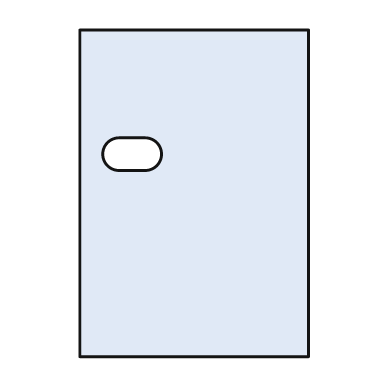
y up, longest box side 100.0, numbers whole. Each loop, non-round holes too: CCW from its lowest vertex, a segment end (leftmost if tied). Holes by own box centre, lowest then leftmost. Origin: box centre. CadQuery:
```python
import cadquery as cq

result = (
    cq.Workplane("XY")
    .moveTo(-35.0, -50.0)
    .lineTo(35.0, -50.0)
    .lineTo(35.0, 50.0)
    .lineTo(-35.0, 50.0)
    .close()
    .moveTo(-23.0, 7.0)
    .lineTo(-15.0, 7.0)
    .threePointArc((-10.0, 12.0), (-15.0, 17.0))
    .lineTo(-23.0, 17.0)
    .threePointArc((-28.0, 12.0), (-23.0, 7.0))
    .close()
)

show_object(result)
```